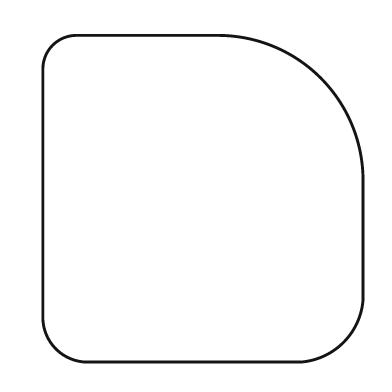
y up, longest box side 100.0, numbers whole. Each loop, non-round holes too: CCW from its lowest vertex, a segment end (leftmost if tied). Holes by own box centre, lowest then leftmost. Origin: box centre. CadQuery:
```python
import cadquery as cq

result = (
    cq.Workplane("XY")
    .moveTo(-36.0, -50.0)
    .lineTo(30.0, -50.0)
    .threePointArc((43.0, -44.0), (49.0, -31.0))
    .lineTo(49.0, 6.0)
    .threePointArc((36.0, 37.0), (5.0, 50.0))
    .lineTo(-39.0, 50.0)
    .threePointArc((-46.0, 47.0), (-49.0, 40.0))
    .lineTo(-49.0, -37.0)
    .threePointArc((-45.0, -46.0), (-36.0, -50.0))
    .close()
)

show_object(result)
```